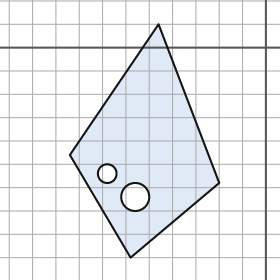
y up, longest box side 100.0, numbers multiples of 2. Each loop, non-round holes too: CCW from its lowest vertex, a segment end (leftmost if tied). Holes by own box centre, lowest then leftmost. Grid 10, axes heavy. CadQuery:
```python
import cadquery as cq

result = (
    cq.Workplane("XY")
    .moveTo(-58.0, -90.0)
    .lineTo(-20.0, -58.0)
    .lineTo(-46.0, 10.0)
    .lineTo(-84.0, -46.0)
    .close()
    .moveTo(-56.0, -64.0)
    .circle(6.0)
    .moveTo(-68.0, -54.0)
    .circle(4.0)
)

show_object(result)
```